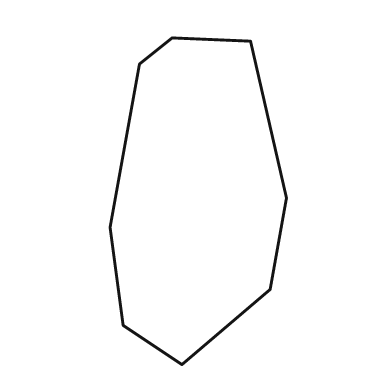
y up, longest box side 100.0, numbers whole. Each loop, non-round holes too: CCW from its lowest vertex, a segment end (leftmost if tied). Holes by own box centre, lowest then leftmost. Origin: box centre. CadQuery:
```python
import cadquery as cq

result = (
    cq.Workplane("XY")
    .moveTo(-5.0, -50.0)
    .lineTo(22.0, -27.0)
    .lineTo(27.0, 1.0)
    .lineTo(16.0, 49.0)
    .lineTo(-8.0, 50.0)
    .lineTo(-18.0, 42.0)
    .lineTo(-27.0, -8.0)
    .lineTo(-23.0, -38.0)
    .close()
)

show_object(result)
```